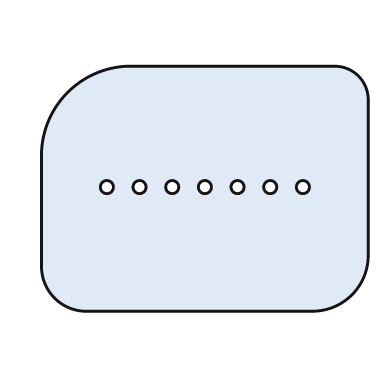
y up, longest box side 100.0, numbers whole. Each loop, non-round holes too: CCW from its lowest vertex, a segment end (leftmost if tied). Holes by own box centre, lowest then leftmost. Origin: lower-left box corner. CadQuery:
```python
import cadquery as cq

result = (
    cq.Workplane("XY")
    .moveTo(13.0, 0.0)
    .lineTo(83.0, 0.0)
    .threePointArc((95.0, 5.0), (100.0, 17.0))
    .lineTo(100.0, 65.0)
    .threePointArc((97.0, 72.0), (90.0, 75.0))
    .lineTo(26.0, 75.0)
    .threePointArc((8.0, 67.0), (0.0, 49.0))
    .lineTo(0.0, 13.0)
    .threePointArc((4.0, 4.0), (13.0, 0.0))
    .close()
    .moveTo(20.0, 38.0)
    .circle(2.0)
    .moveTo(30.0, 38.0)
    .circle(2.0)
    .moveTo(40.0, 38.0)
    .circle(2.0)
    .moveTo(50.0, 38.0)
    .circle(2.0)
    .moveTo(60.0, 38.0)
    .circle(2.0)
    .moveTo(70.0, 38.0)
    .circle(2.0)
    .moveTo(80.0, 38.0)
    .circle(2.0)
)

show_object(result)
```